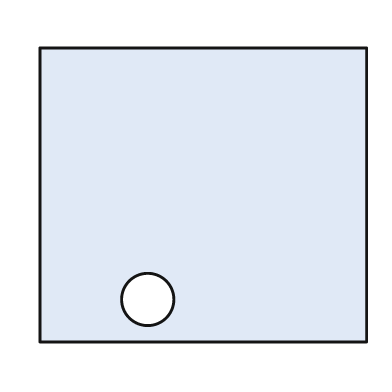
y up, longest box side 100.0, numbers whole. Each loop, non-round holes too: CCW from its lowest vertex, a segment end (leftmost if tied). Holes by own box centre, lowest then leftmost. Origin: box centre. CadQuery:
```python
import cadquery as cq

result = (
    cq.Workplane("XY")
    .moveTo(-50.0, -45.0)
    .lineTo(50.0, -45.0)
    .lineTo(50.0, 45.0)
    .lineTo(-50.0, 45.0)
    .close()
    .moveTo(-17.0, -32.0)
    .circle(8.0)
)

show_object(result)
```